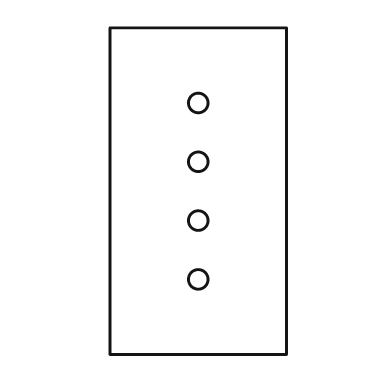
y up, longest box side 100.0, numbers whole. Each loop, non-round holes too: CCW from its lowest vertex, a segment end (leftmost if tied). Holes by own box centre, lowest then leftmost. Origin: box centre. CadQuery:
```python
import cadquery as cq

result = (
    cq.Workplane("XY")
    .moveTo(-27.0, -50.0)
    .lineTo(27.0, -50.0)
    .lineTo(27.0, 50.0)
    .lineTo(-27.0, 50.0)
    .close()
    .moveTo(0.0, -27.0)
    .circle(3.0)
    .moveTo(0.0, -9.0)
    .circle(3.0)
    .moveTo(0.0, 9.0)
    .circle(3.0)
    .moveTo(0.0, 27.0)
    .circle(3.0)
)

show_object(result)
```